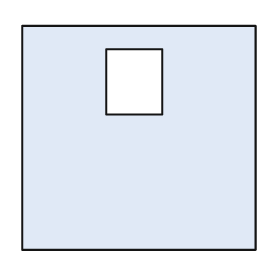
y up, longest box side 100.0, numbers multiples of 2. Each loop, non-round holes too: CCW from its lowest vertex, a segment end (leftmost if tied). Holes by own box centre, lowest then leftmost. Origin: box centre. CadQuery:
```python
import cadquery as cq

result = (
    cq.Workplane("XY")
    .moveTo(-50.0, -48.0)
    .lineTo(50.0, -48.0)
    .lineTo(50.0, 48.0)
    .lineTo(-50.0, 48.0)
    .close()
    .moveTo(-14.0, 10.0)
    .lineTo(10.0, 10.0)
    .lineTo(10.0, 38.0)
    .lineTo(-14.0, 38.0)
    .close()
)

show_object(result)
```